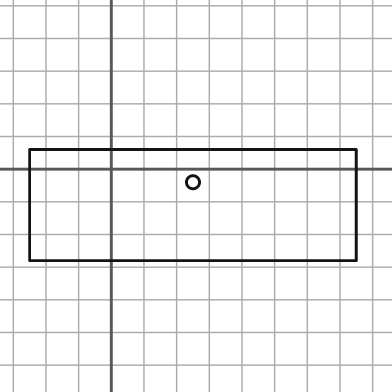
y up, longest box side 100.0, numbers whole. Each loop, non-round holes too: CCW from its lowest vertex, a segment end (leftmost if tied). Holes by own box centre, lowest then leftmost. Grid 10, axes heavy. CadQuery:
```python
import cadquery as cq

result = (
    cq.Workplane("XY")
    .moveTo(-25.0, -28.0)
    .lineTo(75.0, -28.0)
    .lineTo(75.0, 6.0)
    .lineTo(-25.0, 6.0)
    .close()
    .moveTo(25.0, -4.0)
    .circle(2.0)
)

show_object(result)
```